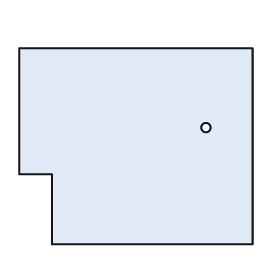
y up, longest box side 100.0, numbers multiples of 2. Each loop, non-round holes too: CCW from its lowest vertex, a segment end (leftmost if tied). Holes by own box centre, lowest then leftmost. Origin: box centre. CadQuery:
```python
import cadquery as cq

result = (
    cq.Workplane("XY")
    .moveTo(-36.0, -42.0)
    .lineTo(50.0, -42.0)
    .lineTo(50.0, 42.0)
    .lineTo(-50.0, 42.0)
    .lineTo(-50.0, -12.0)
    .lineTo(-36.0, -12.0)
    .close()
    .moveTo(30.0, 8.0)
    .circle(2.0)
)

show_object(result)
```